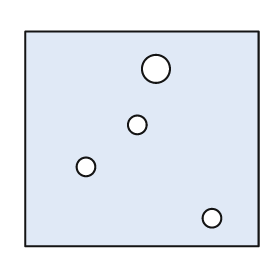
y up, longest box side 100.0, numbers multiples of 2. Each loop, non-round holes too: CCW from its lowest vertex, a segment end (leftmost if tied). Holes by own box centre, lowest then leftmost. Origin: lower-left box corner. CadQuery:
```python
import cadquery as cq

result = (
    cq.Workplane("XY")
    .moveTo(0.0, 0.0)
    .lineTo(100.0, 0.0)
    .lineTo(100.0, 92.0)
    .lineTo(0.0, 92.0)
    .close()
    .moveTo(80.0, 12.0)
    .circle(4.0)
    .moveTo(26.0, 34.0)
    .circle(4.0)
    .moveTo(48.0, 52.0)
    .circle(4.0)
    .moveTo(56.0, 76.0)
    .circle(6.0)
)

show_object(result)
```